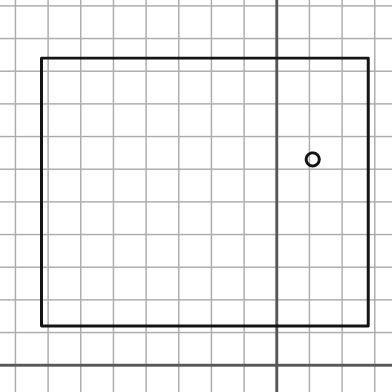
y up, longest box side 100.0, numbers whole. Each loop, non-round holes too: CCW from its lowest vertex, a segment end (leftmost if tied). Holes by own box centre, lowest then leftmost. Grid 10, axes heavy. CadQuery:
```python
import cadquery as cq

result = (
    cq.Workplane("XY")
    .moveTo(-72.0, 12.0)
    .lineTo(28.0, 12.0)
    .lineTo(28.0, 94.0)
    .lineTo(-72.0, 94.0)
    .close()
    .moveTo(11.0, 63.0)
    .circle(2.0)
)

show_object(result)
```